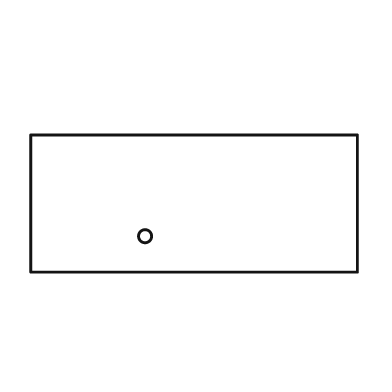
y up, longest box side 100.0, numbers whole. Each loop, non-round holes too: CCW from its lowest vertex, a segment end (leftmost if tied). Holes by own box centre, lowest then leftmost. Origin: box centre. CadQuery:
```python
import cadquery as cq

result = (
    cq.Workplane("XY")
    .moveTo(-50.0, -21.0)
    .lineTo(50.0, -21.0)
    .lineTo(50.0, 21.0)
    .lineTo(-50.0, 21.0)
    .close()
    .moveTo(-15.0, -10.0)
    .circle(2.0)
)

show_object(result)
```